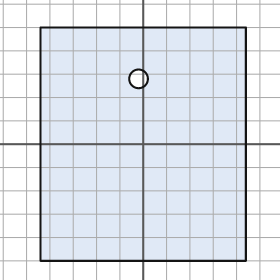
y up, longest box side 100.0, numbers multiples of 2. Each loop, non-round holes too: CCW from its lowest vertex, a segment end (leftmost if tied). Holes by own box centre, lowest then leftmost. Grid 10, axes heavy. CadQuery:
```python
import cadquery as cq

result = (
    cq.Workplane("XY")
    .moveTo(-44.0, -50.0)
    .lineTo(44.0, -50.0)
    .lineTo(44.0, 50.0)
    .lineTo(-44.0, 50.0)
    .close()
    .moveTo(-2.0, 28.0)
    .circle(4.0)
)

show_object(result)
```